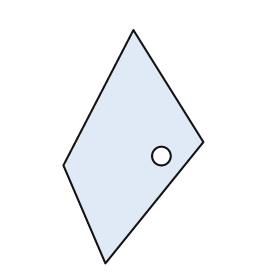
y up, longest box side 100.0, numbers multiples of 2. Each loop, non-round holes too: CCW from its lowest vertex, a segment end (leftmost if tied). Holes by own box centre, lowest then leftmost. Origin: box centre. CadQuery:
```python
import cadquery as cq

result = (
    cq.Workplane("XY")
    .moveTo(-12.0, -50.0)
    .lineTo(30.0, 2.0)
    .lineTo(0.0, 50.0)
    .lineTo(-30.0, -8.0)
    .close()
    .moveTo(12.0, -4.0)
    .circle(4.0)
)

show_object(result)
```